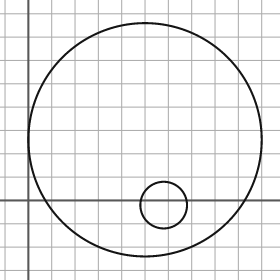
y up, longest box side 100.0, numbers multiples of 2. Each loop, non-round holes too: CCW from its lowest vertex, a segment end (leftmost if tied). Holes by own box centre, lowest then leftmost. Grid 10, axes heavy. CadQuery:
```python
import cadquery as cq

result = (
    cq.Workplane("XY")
    .moveTo(50.0, 26.0)
    .circle(50.0)
    .moveTo(58.0, -2.0)
    .circle(10.0)
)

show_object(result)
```